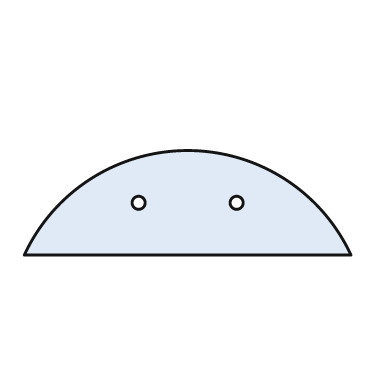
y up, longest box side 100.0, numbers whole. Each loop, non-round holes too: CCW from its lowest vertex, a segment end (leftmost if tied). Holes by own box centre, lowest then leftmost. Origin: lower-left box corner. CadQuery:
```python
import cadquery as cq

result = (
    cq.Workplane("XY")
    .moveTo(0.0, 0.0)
    .lineTo(100.0, 0.0)
    .threePointArc((50.0, 32.0), (0.0, 0.0))
    .close()
    .moveTo(35.0, 16.0)
    .circle(2.0)
    .moveTo(65.0, 16.0)
    .circle(2.0)
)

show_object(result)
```